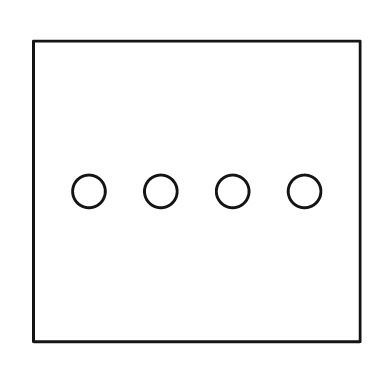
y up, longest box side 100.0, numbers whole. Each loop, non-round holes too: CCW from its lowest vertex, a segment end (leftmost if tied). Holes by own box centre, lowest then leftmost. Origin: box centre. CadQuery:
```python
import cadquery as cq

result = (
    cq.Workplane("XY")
    .moveTo(-50.0, -46.0)
    .lineTo(50.0, -46.0)
    .lineTo(50.0, 46.0)
    .lineTo(-50.0, 46.0)
    .close()
    .moveTo(-33.0, 0.0)
    .circle(5.0)
    .moveTo(-11.0, 0.0)
    .circle(5.0)
    .moveTo(11.0, 0.0)
    .circle(5.0)
    .moveTo(33.0, 0.0)
    .circle(5.0)
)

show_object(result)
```